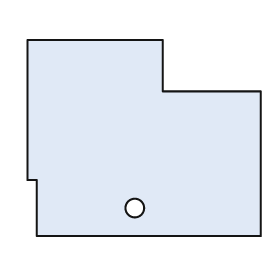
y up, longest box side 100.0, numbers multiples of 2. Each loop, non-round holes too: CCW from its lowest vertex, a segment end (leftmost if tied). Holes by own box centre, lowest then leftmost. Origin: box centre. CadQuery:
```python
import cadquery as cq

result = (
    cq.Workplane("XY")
    .moveTo(-46.0, -42.0)
    .lineTo(50.0, -42.0)
    .lineTo(50.0, 20.0)
    .lineTo(8.0, 20.0)
    .lineTo(8.0, 42.0)
    .lineTo(-50.0, 42.0)
    .lineTo(-50.0, -18.0)
    .lineTo(-46.0, -18.0)
    .close()
    .moveTo(-4.0, -30.0)
    .circle(4.0)
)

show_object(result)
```